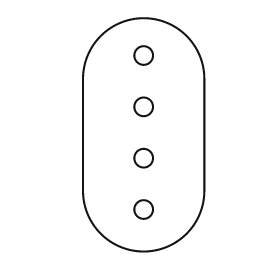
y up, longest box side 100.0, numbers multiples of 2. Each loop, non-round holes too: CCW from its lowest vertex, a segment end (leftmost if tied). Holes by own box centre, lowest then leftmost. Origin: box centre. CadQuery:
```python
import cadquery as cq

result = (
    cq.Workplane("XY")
    .moveTo(-26.0, -24.0)
    .threePointArc((0.0, -50.0), (26.0, -24.0))
    .lineTo(26.0, 24.0)
    .threePointArc((0.0, 50.0), (-26.0, 24.0))
    .close()
    .moveTo(0.0, -32.0)
    .circle(4.0)
    .moveTo(0.0, -10.0)
    .circle(4.0)
    .moveTo(0.0, 12.0)
    .circle(4.0)
    .moveTo(0.0, 34.0)
    .circle(4.0)
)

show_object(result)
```